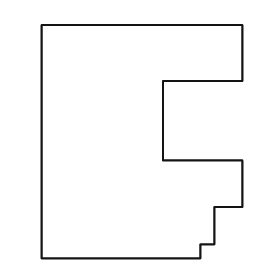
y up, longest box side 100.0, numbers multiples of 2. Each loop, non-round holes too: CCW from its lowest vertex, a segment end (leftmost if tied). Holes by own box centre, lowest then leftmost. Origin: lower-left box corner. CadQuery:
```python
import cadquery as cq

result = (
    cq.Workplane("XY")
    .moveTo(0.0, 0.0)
    .lineTo(68.0, 0.0)
    .lineTo(68.0, 6.0)
    .lineTo(74.0, 6.0)
    .lineTo(74.0, 22.0)
    .lineTo(86.0, 22.0)
    .lineTo(86.0, 42.0)
    .lineTo(52.0, 42.0)
    .lineTo(52.0, 76.0)
    .lineTo(86.0, 76.0)
    .lineTo(86.0, 100.0)
    .lineTo(0.0, 100.0)
    .close()
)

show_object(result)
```